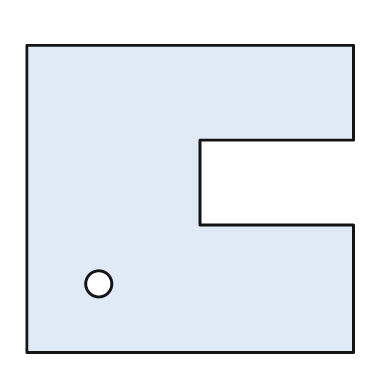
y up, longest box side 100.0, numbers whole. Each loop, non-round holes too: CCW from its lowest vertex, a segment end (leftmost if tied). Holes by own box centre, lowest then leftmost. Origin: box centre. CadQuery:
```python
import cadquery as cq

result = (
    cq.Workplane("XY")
    .moveTo(-50.0, -47.0)
    .lineTo(50.0, -47.0)
    .lineTo(50.0, -8.0)
    .lineTo(3.0, -8.0)
    .lineTo(3.0, 18.0)
    .lineTo(50.0, 18.0)
    .lineTo(50.0, 47.0)
    .lineTo(-50.0, 47.0)
    .close()
    .moveTo(-28.0, -26.0)
    .circle(4.0)
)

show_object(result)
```